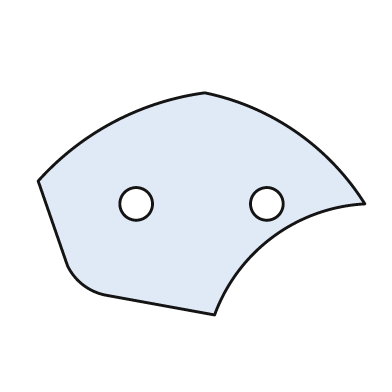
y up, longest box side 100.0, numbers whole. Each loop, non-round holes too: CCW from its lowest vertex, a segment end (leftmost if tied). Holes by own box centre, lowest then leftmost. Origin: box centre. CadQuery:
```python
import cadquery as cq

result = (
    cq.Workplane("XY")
    .moveTo(4.0, -34.0)
    .threePointArc((22.0, -10.0), (50.0, 0.0))
    .threePointArc((29.0, 22.0), (1.0, 34.0))
    .threePointArc((-27.0, 25.0), (-50.0, 7.0))
    .lineTo(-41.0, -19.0)
    .threePointArc((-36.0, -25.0), (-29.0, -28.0))
    .close()
    .moveTo(-20.0, 0.0)
    .circle(5.0)
    .moveTo(20.0, 0.0)
    .circle(5.0)
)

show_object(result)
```